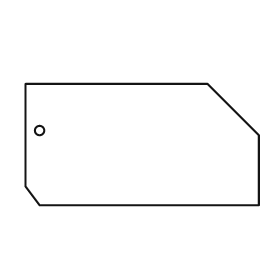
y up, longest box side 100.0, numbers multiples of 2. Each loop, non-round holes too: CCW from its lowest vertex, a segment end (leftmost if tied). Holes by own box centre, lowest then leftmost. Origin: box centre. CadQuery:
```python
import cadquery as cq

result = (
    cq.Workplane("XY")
    .moveTo(-44.0, -26.0)
    .lineTo(50.0, -26.0)
    .lineTo(50.0, 4.0)
    .lineTo(28.0, 26.0)
    .lineTo(-50.0, 26.0)
    .lineTo(-50.0, -18.0)
    .close()
    .moveTo(-44.0, 6.0)
    .circle(2.0)
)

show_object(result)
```